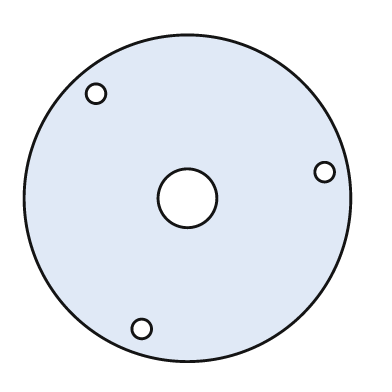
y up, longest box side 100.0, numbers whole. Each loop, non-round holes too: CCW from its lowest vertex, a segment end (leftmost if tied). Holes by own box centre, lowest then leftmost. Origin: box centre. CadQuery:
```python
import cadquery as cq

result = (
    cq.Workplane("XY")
    .moveTo(0.0, 0.0)
    .circle(50.0)
    .moveTo(-14.0, -40.0)
    .circle(3.0)
    .moveTo(0.0, 0.0)
    .circle(9.0)
    .moveTo(42.0, 8.0)
    .circle(3.0)
    .moveTo(-28.0, 32.0)
    .circle(3.0)
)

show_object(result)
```